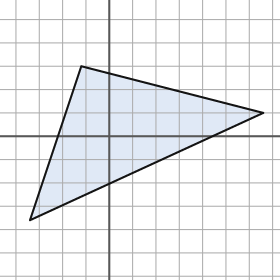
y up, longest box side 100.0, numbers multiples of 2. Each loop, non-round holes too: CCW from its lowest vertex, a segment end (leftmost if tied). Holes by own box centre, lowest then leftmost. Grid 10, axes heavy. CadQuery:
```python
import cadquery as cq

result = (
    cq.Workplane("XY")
    .moveTo(-34.0, -36.0)
    .lineTo(66.0, 10.0)
    .lineTo(-12.0, 30.0)
    .close()
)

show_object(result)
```